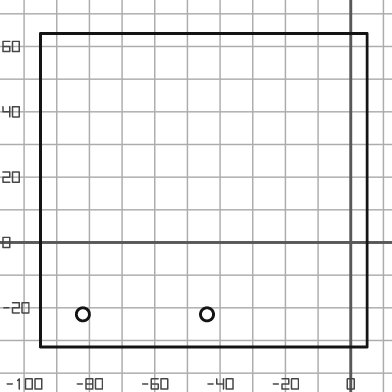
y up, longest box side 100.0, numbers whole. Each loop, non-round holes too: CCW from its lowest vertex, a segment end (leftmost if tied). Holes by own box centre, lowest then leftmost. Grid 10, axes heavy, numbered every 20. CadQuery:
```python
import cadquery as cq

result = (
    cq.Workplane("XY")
    .moveTo(-95.0, -32.0)
    .lineTo(5.0, -32.0)
    .lineTo(5.0, 64.0)
    .lineTo(-95.0, 64.0)
    .close()
    .moveTo(-82.0, -22.0)
    .circle(2.0)
    .moveTo(-44.0, -22.0)
    .circle(2.0)
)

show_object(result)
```